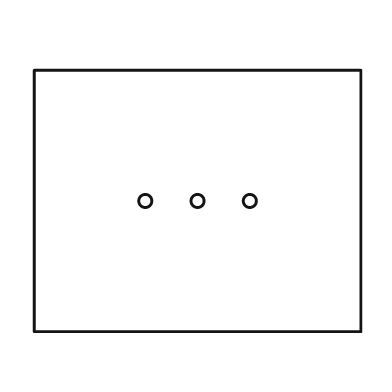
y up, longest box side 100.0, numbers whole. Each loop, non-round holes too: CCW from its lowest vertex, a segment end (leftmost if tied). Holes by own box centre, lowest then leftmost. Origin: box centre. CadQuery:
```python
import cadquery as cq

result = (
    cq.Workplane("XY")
    .moveTo(-50.0, -40.0)
    .lineTo(50.0, -40.0)
    .lineTo(50.0, 40.0)
    .lineTo(-50.0, 40.0)
    .close()
    .moveTo(-16.0, 0.0)
    .circle(2.0)
    .moveTo(0.0, 0.0)
    .circle(2.0)
    .moveTo(16.0, 0.0)
    .circle(2.0)
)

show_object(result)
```